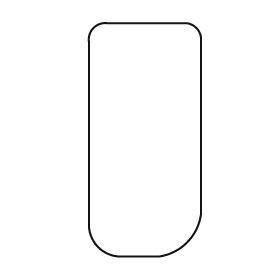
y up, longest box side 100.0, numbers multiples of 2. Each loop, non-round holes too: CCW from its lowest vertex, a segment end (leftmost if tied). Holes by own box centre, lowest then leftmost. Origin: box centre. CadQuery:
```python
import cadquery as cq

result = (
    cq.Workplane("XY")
    .moveTo(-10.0, -50.0)
    .lineTo(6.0, -50.0)
    .threePointArc((18.0, -44.0), (24.0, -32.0))
    .lineTo(24.0, 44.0)
    .threePointArc((22.0, 48.0), (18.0, 50.0))
    .lineTo(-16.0, 50.0)
    .threePointArc((-22.0, 48.0), (-24.0, 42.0))
    .lineTo(-24.0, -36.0)
    .threePointArc((-20.0, -46.0), (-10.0, -50.0))
    .close()
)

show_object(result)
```